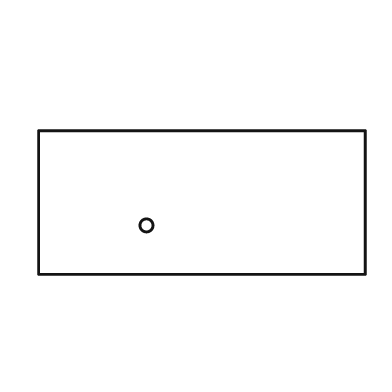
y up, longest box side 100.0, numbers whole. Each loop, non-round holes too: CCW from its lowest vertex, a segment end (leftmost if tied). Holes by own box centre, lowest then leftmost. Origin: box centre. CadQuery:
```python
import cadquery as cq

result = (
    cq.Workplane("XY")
    .moveTo(-50.0, -22.0)
    .lineTo(50.0, -22.0)
    .lineTo(50.0, 22.0)
    .lineTo(-50.0, 22.0)
    .close()
    .moveTo(-17.0, -7.0)
    .circle(2.0)
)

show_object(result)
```